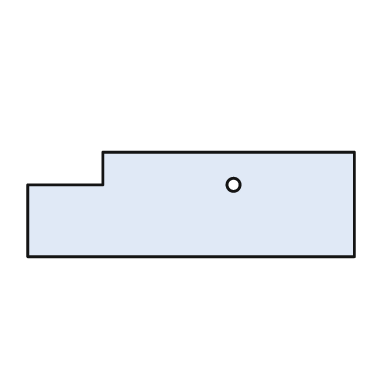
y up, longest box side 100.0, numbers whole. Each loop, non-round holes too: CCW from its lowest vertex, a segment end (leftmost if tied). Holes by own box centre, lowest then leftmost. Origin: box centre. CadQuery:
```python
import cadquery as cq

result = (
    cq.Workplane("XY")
    .moveTo(-50.0, -16.0)
    .lineTo(50.0, -16.0)
    .lineTo(50.0, 16.0)
    .lineTo(-27.0, 16.0)
    .lineTo(-27.0, 6.0)
    .lineTo(-50.0, 6.0)
    .close()
    .moveTo(13.0, 6.0)
    .circle(2.0)
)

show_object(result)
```